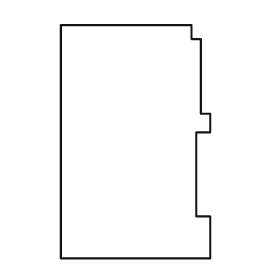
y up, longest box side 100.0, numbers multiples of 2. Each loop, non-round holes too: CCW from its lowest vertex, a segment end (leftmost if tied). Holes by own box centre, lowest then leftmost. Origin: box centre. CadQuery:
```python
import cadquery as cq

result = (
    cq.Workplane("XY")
    .moveTo(-32.0, -50.0)
    .lineTo(32.0, -50.0)
    .lineTo(32.0, -32.0)
    .lineTo(26.0, -32.0)
    .lineTo(26.0, 4.0)
    .lineTo(32.0, 4.0)
    .lineTo(32.0, 12.0)
    .lineTo(28.0, 12.0)
    .lineTo(28.0, 44.0)
    .lineTo(24.0, 44.0)
    .lineTo(24.0, 50.0)
    .lineTo(-32.0, 50.0)
    .close()
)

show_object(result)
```